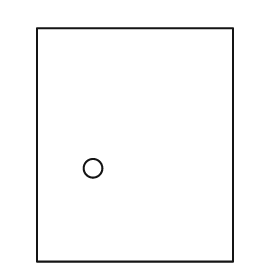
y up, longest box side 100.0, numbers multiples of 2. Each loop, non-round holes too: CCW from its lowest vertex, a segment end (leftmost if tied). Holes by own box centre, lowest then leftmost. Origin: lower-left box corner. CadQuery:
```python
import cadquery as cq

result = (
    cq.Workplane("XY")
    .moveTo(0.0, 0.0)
    .lineTo(84.0, 0.0)
    .lineTo(84.0, 100.0)
    .lineTo(0.0, 100.0)
    .close()
    .moveTo(24.0, 40.0)
    .circle(4.0)
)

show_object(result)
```